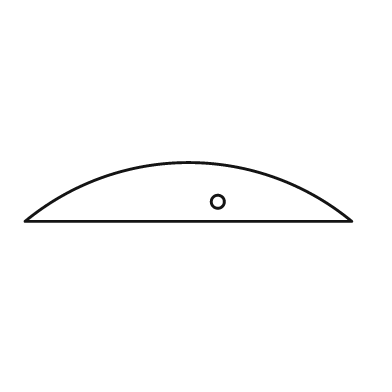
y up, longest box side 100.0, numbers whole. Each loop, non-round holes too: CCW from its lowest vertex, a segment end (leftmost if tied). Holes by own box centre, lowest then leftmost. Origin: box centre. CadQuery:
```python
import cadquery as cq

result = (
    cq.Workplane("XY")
    .moveTo(-50.0, -9.0)
    .lineTo(50.0, -9.0)
    .threePointArc((0.0, 9.0), (-50.0, -9.0))
    .close()
    .moveTo(9.0, -3.0)
    .circle(2.0)
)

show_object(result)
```